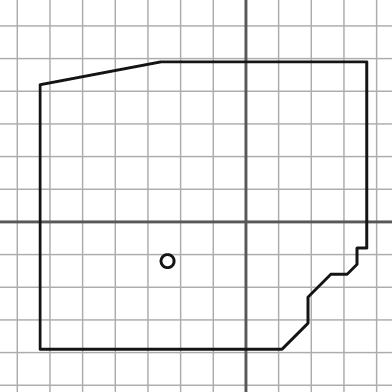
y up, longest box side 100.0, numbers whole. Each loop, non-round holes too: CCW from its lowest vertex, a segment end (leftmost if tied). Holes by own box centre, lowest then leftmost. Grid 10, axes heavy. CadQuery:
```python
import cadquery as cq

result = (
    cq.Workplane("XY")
    .moveTo(-63.0, -39.0)
    .lineTo(11.0, -39.0)
    .lineTo(19.0, -31.0)
    .lineTo(19.0, -23.0)
    .lineTo(26.0, -16.0)
    .lineTo(31.0, -16.0)
    .lineTo(34.0, -13.0)
    .lineTo(34.0, -8.0)
    .lineTo(37.0, -8.0)
    .lineTo(37.0, 49.0)
    .lineTo(-26.0, 49.0)
    .lineTo(-63.0, 42.0)
    .close()
    .moveTo(-24.0, -12.0)
    .circle(2.0)
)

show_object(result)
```